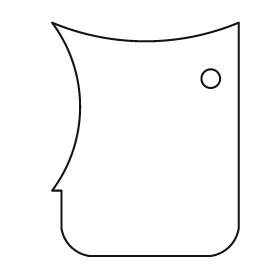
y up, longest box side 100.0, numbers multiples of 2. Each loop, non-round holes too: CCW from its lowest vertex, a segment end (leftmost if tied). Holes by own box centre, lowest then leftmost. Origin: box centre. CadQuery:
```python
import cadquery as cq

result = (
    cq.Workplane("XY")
    .moveTo(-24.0, -50.0)
    .lineTo(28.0, -50.0)
    .threePointArc((36.0, -46.0), (40.0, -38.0))
    .lineTo(40.0, 50.0)
    .threePointArc((0.0, 42.0), (-40.0, 50.0))
    .threePointArc((-28.0, 14.0), (-40.0, -22.0))
    .lineTo(-36.0, -22.0)
    .lineTo(-36.0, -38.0)
    .threePointArc((-32.0, -46.0), (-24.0, -50.0))
    .close()
    .moveTo(28.0, 26.0)
    .circle(4.0)
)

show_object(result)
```